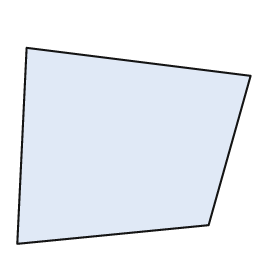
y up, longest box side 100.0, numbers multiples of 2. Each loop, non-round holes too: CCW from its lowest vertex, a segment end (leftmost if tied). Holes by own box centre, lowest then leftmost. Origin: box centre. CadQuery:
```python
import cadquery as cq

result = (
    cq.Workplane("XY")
    .moveTo(-50.0, -42.0)
    .lineTo(32.0, -34.0)
    .lineTo(50.0, 30.0)
    .lineTo(-46.0, 42.0)
    .close()
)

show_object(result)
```